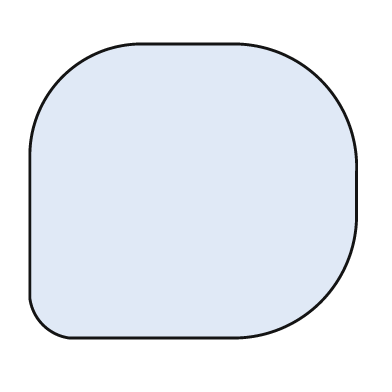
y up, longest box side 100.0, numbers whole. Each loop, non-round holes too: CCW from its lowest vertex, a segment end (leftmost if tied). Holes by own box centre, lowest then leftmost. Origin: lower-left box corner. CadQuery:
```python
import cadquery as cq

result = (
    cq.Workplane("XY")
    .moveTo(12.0, 0.0)
    .lineTo(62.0, 0.0)
    .threePointArc((89.0, 11.0), (100.0, 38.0))
    .lineTo(100.0, 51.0)
    .threePointArc((89.0, 79.0), (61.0, 90.0))
    .lineTo(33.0, 90.0)
    .threePointArc((10.0, 80.0), (0.0, 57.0))
    .lineTo(0.0, 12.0)
    .threePointArc((4.0, 4.0), (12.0, 0.0))
    .close()
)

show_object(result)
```